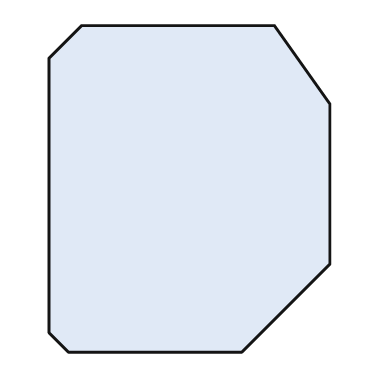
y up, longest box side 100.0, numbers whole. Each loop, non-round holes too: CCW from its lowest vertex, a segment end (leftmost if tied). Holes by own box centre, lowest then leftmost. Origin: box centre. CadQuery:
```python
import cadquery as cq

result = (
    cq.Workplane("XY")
    .moveTo(-37.0, -50.0)
    .lineTo(16.0, -50.0)
    .lineTo(43.0, -23.0)
    .lineTo(43.0, 26.0)
    .lineTo(26.0, 50.0)
    .lineTo(-33.0, 50.0)
    .lineTo(-43.0, 40.0)
    .lineTo(-43.0, -44.0)
    .close()
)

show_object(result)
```